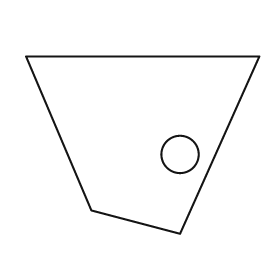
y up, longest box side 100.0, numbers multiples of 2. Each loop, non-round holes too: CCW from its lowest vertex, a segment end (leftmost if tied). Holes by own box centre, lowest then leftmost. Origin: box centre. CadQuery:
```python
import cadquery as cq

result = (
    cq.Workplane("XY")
    .moveTo(16.0, -38.0)
    .lineTo(50.0, 38.0)
    .lineTo(-50.0, 38.0)
    .lineTo(-22.0, -28.0)
    .close()
    .moveTo(16.0, -4.0)
    .circle(8.0)
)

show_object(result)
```